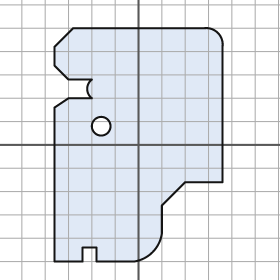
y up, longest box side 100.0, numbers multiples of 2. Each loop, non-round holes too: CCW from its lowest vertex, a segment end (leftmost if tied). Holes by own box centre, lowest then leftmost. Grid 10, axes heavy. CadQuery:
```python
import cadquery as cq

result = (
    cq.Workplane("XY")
    .moveTo(-36.0, -50.0)
    .lineTo(-24.0, -50.0)
    .lineTo(-24.0, -44.0)
    .lineTo(-18.0, -44.0)
    .lineTo(-18.0, -50.0)
    .lineTo(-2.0, -50.0)
    .threePointArc((6.0, -46.0), (10.0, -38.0))
    .lineTo(10.0, -26.0)
    .lineTo(20.0, -16.0)
    .lineTo(36.0, -16.0)
    .lineTo(36.0, 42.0)
    .threePointArc((34.0, 48.0), (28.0, 50.0))
    .lineTo(-28.0, 50.0)
    .lineTo(-36.0, 42.0)
    .lineTo(-36.0, 34.0)
    .lineTo(-30.0, 28.0)
    .lineTo(-20.0, 28.0)
    .threePointArc((-22.0, 24.0), (-20.0, 20.0))
    .lineTo(-30.0, 20.0)
    .lineTo(-36.0, 16.0)
    .close()
    .moveTo(-16.0, 8.0)
    .circle(4.0)
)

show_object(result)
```